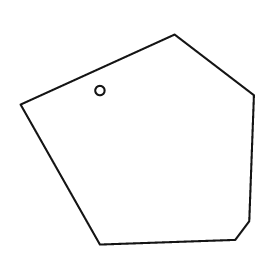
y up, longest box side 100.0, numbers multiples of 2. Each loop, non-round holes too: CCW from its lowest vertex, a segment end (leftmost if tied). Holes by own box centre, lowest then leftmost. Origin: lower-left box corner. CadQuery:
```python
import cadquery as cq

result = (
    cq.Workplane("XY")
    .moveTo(34.0, 0.0)
    .lineTo(92.0, 2.0)
    .lineTo(98.0, 10.0)
    .lineTo(100.0, 64.0)
    .lineTo(66.0, 90.0)
    .lineTo(0.0, 60.0)
    .close()
    .moveTo(34.0, 66.0)
    .circle(2.0)
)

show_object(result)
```